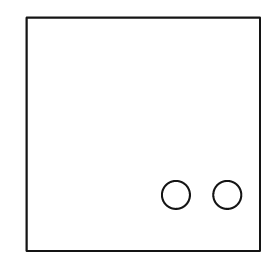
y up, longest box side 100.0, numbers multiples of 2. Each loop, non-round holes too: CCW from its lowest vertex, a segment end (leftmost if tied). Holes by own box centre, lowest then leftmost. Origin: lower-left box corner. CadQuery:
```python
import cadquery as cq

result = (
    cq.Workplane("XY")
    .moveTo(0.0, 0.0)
    .lineTo(100.0, 0.0)
    .lineTo(100.0, 100.0)
    .lineTo(0.0, 100.0)
    .close()
    .moveTo(64.0, 24.0)
    .circle(6.0)
    .moveTo(86.0, 24.0)
    .circle(6.0)
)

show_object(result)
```